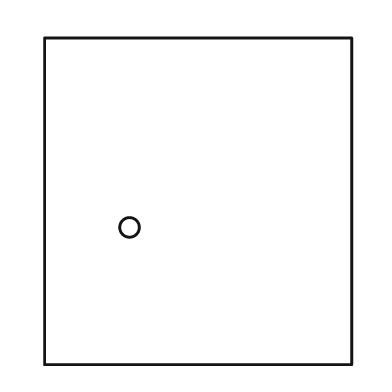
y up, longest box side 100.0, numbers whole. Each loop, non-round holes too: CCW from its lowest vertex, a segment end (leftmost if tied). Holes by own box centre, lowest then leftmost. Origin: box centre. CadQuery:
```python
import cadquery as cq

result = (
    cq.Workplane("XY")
    .moveTo(-47.0, -50.0)
    .lineTo(47.0, -50.0)
    .lineTo(47.0, 50.0)
    .lineTo(-47.0, 50.0)
    .close()
    .moveTo(-21.0, -8.0)
    .circle(3.0)
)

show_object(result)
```